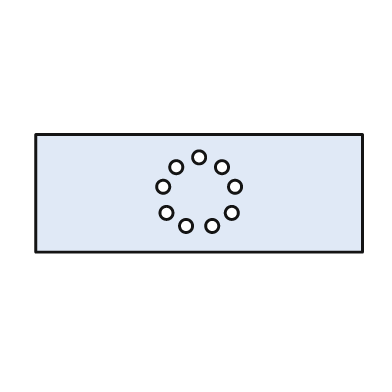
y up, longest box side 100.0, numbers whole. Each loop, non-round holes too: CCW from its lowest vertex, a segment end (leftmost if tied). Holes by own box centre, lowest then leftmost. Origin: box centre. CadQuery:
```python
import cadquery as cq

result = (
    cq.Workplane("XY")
    .moveTo(-50.0, -18.0)
    .lineTo(50.0, -18.0)
    .lineTo(50.0, 18.0)
    .lineTo(-50.0, 18.0)
    .close()
    .moveTo(-4.0, -10.0)
    .circle(2.0)
    .moveTo(4.0, -10.0)
    .circle(2.0)
    .moveTo(-10.0, -6.0)
    .circle(2.0)
    .moveTo(10.0, -6.0)
    .circle(2.0)
    .moveTo(-11.0, 2.0)
    .circle(2.0)
    .moveTo(11.0, 2.0)
    .circle(2.0)
    .moveTo(-7.0, 8.0)
    .circle(2.0)
    .moveTo(7.0, 8.0)
    .circle(2.0)
    .moveTo(0.0, 11.0)
    .circle(2.0)
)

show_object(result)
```